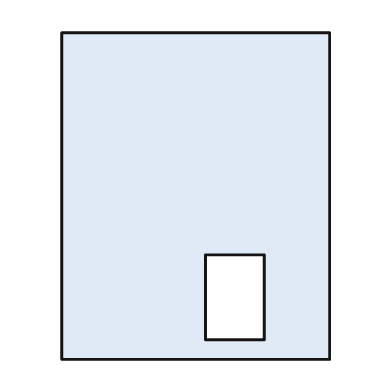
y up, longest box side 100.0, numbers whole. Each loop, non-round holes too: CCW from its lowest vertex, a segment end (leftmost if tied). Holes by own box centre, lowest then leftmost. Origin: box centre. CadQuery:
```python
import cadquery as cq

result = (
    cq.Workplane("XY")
    .moveTo(-41.0, -50.0)
    .lineTo(41.0, -50.0)
    .lineTo(41.0, 50.0)
    .lineTo(-41.0, 50.0)
    .close()
    .moveTo(3.0, -44.0)
    .lineTo(21.0, -44.0)
    .lineTo(21.0, -18.0)
    .lineTo(3.0, -18.0)
    .close()
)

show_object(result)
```